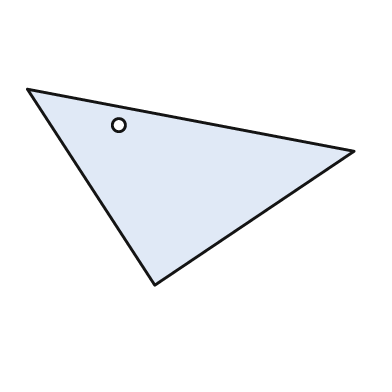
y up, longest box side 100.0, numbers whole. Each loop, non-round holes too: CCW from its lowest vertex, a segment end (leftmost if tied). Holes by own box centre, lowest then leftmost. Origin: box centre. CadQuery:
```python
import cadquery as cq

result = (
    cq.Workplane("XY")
    .moveTo(-11.0, -30.0)
    .lineTo(50.0, 11.0)
    .lineTo(-50.0, 30.0)
    .close()
    .moveTo(-22.0, 19.0)
    .circle(2.0)
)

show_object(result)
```